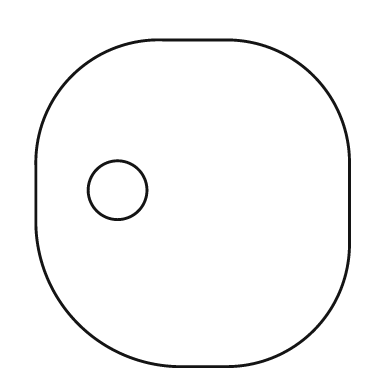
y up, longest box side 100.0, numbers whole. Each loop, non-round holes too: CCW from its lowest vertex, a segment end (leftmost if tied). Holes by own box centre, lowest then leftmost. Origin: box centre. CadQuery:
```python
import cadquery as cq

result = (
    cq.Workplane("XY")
    .moveTo(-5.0, -50.0)
    .lineTo(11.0, -50.0)
    .threePointArc((37.0, -39.0), (48.0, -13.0))
    .lineTo(48.0, 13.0)
    .threePointArc((37.0, 39.0), (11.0, 50.0))
    .lineTo(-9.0, 50.0)
    .threePointArc((-37.0, 39.0), (-48.0, 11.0))
    .lineTo(-48.0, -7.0)
    .threePointArc((-35.0, -37.0), (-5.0, -50.0))
    .close()
    .moveTo(-23.0, 4.0)
    .circle(9.0)
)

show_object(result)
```